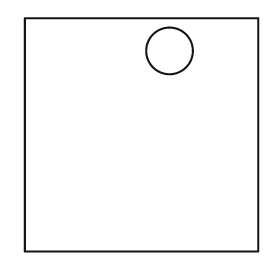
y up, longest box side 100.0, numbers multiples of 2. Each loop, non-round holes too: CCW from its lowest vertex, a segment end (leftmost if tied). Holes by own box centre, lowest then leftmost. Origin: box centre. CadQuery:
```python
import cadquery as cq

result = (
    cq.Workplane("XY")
    .moveTo(-50.0, -50.0)
    .lineTo(50.0, -50.0)
    .lineTo(50.0, 50.0)
    .lineTo(-50.0, 50.0)
    .close()
    .moveTo(12.0, 36.0)
    .circle(10.0)
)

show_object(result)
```